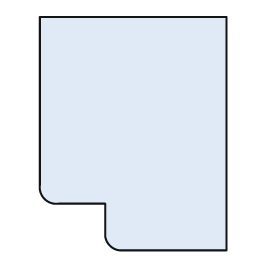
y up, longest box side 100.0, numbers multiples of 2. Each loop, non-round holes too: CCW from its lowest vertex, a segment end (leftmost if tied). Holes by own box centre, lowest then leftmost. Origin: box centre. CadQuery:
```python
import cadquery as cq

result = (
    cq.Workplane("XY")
    .moveTo(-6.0, -50.0)
    .lineTo(40.0, -50.0)
    .lineTo(40.0, 50.0)
    .lineTo(-40.0, 50.0)
    .lineTo(-40.0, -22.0)
    .threePointArc((-38.0, -28.0), (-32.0, -30.0))
    .lineTo(-12.0, -30.0)
    .lineTo(-12.0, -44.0)
    .threePointArc((-10.0, -48.0), (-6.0, -50.0))
    .close()
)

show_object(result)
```